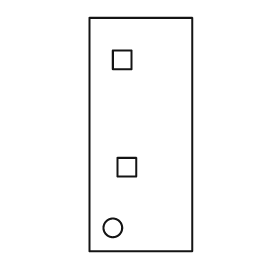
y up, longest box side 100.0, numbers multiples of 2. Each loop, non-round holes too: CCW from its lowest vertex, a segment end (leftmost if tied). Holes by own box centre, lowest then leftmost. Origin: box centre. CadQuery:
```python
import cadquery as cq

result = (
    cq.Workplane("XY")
    .moveTo(-22.0, -50.0)
    .lineTo(22.0, -50.0)
    .lineTo(22.0, 50.0)
    .lineTo(-22.0, 50.0)
    .close()
    .moveTo(-12.0, -40.0)
    .circle(4.0)
    .moveTo(-10.0, -18.0)
    .lineTo(-2.0, -18.0)
    .lineTo(-2.0, -10.0)
    .lineTo(-10.0, -10.0)
    .close()
    .moveTo(-12.0, 28.0)
    .lineTo(-4.0, 28.0)
    .lineTo(-4.0, 36.0)
    .lineTo(-12.0, 36.0)
    .close()
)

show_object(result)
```